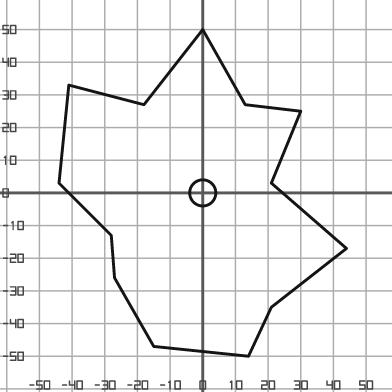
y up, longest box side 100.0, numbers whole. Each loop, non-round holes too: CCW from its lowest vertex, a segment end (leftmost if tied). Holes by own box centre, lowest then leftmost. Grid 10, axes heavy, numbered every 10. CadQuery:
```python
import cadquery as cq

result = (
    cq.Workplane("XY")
    .moveTo(14.0, -50.0)
    .lineTo(21.0, -35.0)
    .lineTo(44.0, -17.0)
    .lineTo(21.0, 3.0)
    .lineTo(30.0, 25.0)
    .lineTo(13.0, 27.0)
    .lineTo(0.0, 50.0)
    .lineTo(-18.0, 27.0)
    .lineTo(-41.0, 33.0)
    .lineTo(-44.0, 3.0)
    .lineTo(-28.0, -13.0)
    .lineTo(-27.0, -26.0)
    .lineTo(-15.0, -47.0)
    .close()
    .moveTo(0.0, 0.0)
    .circle(4.0)
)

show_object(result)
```